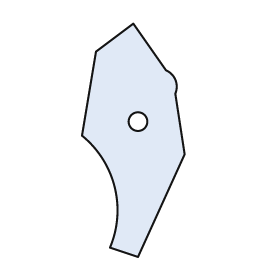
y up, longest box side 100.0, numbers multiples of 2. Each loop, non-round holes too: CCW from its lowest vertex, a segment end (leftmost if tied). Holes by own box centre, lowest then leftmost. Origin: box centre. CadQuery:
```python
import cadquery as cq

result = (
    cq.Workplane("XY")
    .moveTo(2.0, -50.0)
    .lineTo(22.0, -6.0)
    .lineTo(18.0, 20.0)
    .threePointArc((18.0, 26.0), (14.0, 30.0))
    .lineTo(0.0, 50.0)
    .lineTo(-16.0, 38.0)
    .lineTo(-22.0, 2.0)
    .threePointArc((-8.0, -20.0), (-10.0, -46.0))
    .close()
    .moveTo(2.0, 8.0)
    .circle(4.0)
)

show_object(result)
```